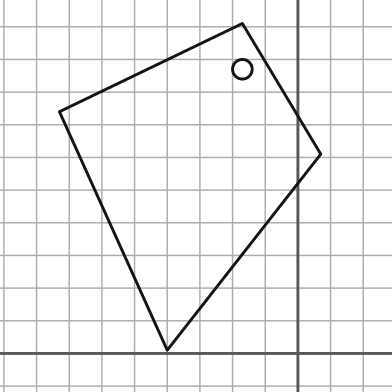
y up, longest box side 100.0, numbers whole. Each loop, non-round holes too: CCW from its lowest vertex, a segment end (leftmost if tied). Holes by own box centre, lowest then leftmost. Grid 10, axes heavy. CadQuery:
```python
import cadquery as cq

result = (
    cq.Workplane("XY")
    .moveTo(-40.0, 1.0)
    .lineTo(7.0, 61.0)
    .lineTo(-17.0, 101.0)
    .lineTo(-73.0, 74.0)
    .close()
    .moveTo(-17.0, 87.0)
    .circle(3.0)
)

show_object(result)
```